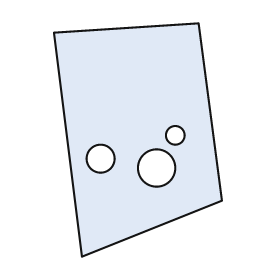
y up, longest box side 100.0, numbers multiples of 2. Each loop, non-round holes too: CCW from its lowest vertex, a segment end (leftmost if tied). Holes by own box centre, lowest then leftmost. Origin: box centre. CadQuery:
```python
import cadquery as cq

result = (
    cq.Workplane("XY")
    .moveTo(-24.0, -50.0)
    .lineTo(36.0, -26.0)
    .lineTo(26.0, 50.0)
    .lineTo(-36.0, 46.0)
    .close()
    .moveTo(8.0, -12.0)
    .circle(8.0)
    .moveTo(-16.0, -8.0)
    .circle(6.0)
    .moveTo(16.0, 2.0)
    .circle(4.0)
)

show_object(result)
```